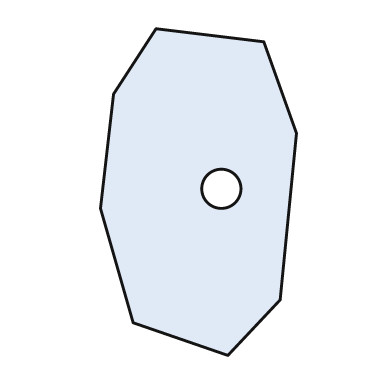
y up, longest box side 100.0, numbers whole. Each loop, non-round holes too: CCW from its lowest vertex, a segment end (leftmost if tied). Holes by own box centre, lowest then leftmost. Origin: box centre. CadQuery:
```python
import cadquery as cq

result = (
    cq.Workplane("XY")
    .moveTo(9.0, -50.0)
    .lineTo(25.0, -33.0)
    .lineTo(30.0, 18.0)
    .lineTo(20.0, 46.0)
    .lineTo(-13.0, 50.0)
    .lineTo(-26.0, 30.0)
    .lineTo(-30.0, -5.0)
    .lineTo(-20.0, -40.0)
    .close()
    .moveTo(7.0, 1.0)
    .circle(6.0)
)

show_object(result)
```